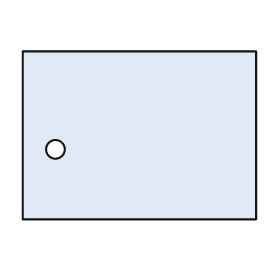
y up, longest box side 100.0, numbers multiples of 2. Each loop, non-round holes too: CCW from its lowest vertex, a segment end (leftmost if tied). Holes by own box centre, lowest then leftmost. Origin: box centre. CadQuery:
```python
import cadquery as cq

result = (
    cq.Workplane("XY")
    .moveTo(-50.0, -36.0)
    .lineTo(50.0, -36.0)
    .lineTo(50.0, 36.0)
    .lineTo(-50.0, 36.0)
    .close()
    .moveTo(-36.0, -6.0)
    .circle(4.0)
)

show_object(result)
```